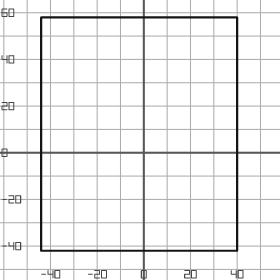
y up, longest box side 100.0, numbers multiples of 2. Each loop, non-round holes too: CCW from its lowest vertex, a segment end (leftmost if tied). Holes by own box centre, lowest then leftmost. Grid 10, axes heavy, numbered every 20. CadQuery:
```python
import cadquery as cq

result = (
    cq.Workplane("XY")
    .moveTo(-44.0, -42.0)
    .lineTo(40.0, -42.0)
    .lineTo(40.0, 58.0)
    .lineTo(-44.0, 58.0)
    .close()
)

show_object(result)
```